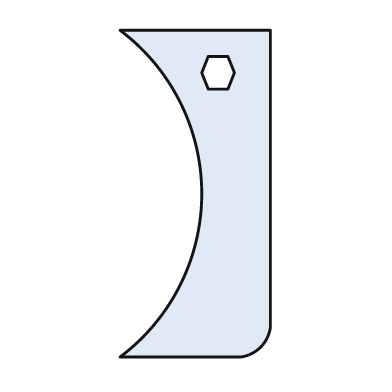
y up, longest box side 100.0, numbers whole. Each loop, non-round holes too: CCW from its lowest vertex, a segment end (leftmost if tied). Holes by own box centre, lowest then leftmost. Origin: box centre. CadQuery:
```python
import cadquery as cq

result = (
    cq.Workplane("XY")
    .moveTo(-23.0, -50.0)
    .lineTo(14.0, -50.0)
    .threePointArc((20.0, -47.0), (23.0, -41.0))
    .lineTo(23.0, 50.0)
    .lineTo(-23.0, 50.0)
    .threePointArc((2.0, 0.0), (-23.0, -50.0))
    .close()
    .moveTo(4.0, 32.0)
    .lineTo(10.0, 32.0)
    .lineTo(12.0, 37.0)
    .lineTo(10.0, 42.0)
    .lineTo(4.0, 42.0)
    .lineTo(2.0, 37.0)
    .close()
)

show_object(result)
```